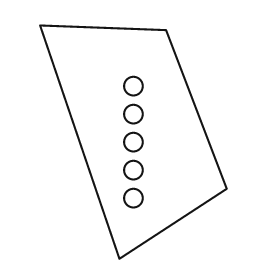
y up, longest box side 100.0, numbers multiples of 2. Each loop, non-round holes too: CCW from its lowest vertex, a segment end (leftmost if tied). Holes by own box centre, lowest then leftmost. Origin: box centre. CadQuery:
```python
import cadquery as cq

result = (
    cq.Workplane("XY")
    .moveTo(-6.0, -50.0)
    .lineTo(40.0, -20.0)
    .lineTo(14.0, 48.0)
    .lineTo(-40.0, 50.0)
    .close()
    .moveTo(0.0, -24.0)
    .circle(4.0)
    .moveTo(0.0, -12.0)
    .circle(4.0)
    .moveTo(0.0, 0.0)
    .circle(4.0)
    .moveTo(0.0, 12.0)
    .circle(4.0)
    .moveTo(0.0, 24.0)
    .circle(4.0)
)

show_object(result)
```